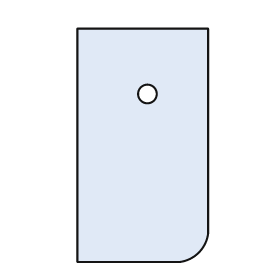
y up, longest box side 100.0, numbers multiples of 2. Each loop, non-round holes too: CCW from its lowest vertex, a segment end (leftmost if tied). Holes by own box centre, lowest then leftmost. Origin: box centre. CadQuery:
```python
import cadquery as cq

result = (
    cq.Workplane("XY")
    .moveTo(-28.0, -50.0)
    .lineTo(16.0, -50.0)
    .threePointArc((24.0, -46.0), (28.0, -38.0))
    .lineTo(28.0, 50.0)
    .lineTo(-28.0, 50.0)
    .close()
    .moveTo(2.0, 22.0)
    .circle(4.0)
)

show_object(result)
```